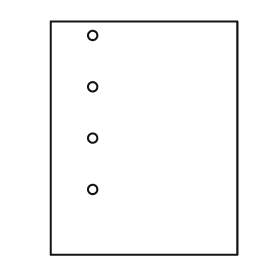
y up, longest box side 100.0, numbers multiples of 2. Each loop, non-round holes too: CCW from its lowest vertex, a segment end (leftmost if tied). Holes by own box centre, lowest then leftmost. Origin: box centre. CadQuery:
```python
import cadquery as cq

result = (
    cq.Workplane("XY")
    .moveTo(-40.0, -50.0)
    .lineTo(40.0, -50.0)
    .lineTo(40.0, 50.0)
    .lineTo(-40.0, 50.0)
    .close()
    .moveTo(-22.0, -22.0)
    .circle(2.0)
    .moveTo(-22.0, 0.0)
    .circle(2.0)
    .moveTo(-22.0, 22.0)
    .circle(2.0)
    .moveTo(-22.0, 44.0)
    .circle(2.0)
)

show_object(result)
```